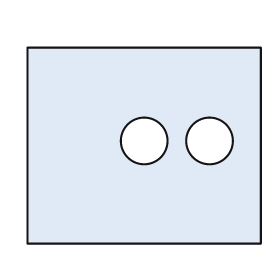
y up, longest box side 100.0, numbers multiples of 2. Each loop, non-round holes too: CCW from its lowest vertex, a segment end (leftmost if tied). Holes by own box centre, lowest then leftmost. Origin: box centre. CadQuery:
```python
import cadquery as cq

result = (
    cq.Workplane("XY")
    .moveTo(-50.0, -42.0)
    .lineTo(50.0, -42.0)
    .lineTo(50.0, 42.0)
    .lineTo(-50.0, 42.0)
    .close()
    .moveTo(0.0, 2.0)
    .circle(10.0)
    .moveTo(28.0, 2.0)
    .circle(10.0)
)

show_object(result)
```